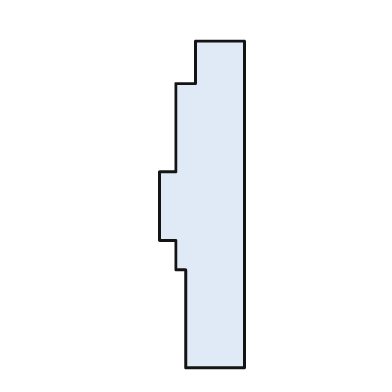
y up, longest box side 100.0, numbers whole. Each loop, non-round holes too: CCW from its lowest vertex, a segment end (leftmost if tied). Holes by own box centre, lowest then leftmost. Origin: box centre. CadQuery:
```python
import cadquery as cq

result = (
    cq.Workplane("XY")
    .moveTo(-5.0, -50.0)
    .lineTo(13.0, -50.0)
    .lineTo(13.0, 50.0)
    .lineTo(-2.0, 50.0)
    .lineTo(-2.0, 37.0)
    .lineTo(-8.0, 37.0)
    .lineTo(-8.0, 10.0)
    .lineTo(-13.0, 10.0)
    .lineTo(-13.0, -11.0)
    .lineTo(-8.0, -11.0)
    .lineTo(-8.0, -20.0)
    .lineTo(-5.0, -20.0)
    .close()
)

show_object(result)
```